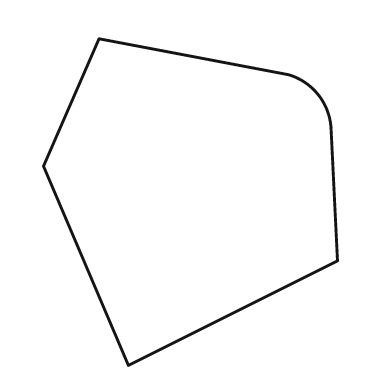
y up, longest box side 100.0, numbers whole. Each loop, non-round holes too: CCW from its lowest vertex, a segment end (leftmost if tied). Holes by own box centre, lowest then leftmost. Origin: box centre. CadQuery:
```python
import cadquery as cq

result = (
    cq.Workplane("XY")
    .moveTo(-19.0, -50.0)
    .lineTo(45.0, -18.0)
    .lineTo(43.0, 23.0)
    .threePointArc((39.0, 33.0), (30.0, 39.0))
    .lineTo(-28.0, 50.0)
    .lineTo(-45.0, 11.0)
    .close()
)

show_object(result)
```